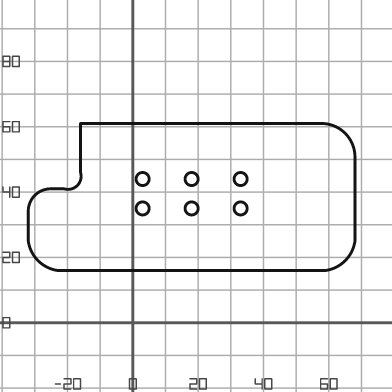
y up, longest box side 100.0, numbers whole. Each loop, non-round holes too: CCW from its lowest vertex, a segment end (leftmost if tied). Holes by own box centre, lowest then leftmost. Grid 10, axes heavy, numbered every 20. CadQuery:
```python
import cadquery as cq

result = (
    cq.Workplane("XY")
    .moveTo(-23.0, 16.0)
    .lineTo(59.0, 16.0)
    .threePointArc((65.0, 19.0), (68.0, 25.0))
    .lineTo(68.0, 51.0)
    .threePointArc((65.0, 58.0), (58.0, 61.0))
    .lineTo(-16.0, 61.0)
    .lineTo(-16.0, 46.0)
    .threePointArc((-17.0, 42.0), (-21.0, 41.0))
    .lineTo(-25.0, 41.0)
    .threePointArc((-30.0, 39.0), (-32.0, 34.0))
    .lineTo(-32.0, 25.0)
    .threePointArc((-29.0, 19.0), (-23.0, 16.0))
    .close()
    .moveTo(3.0, 35.0)
    .circle(2.0)
    .moveTo(18.0, 35.0)
    .circle(2.0)
    .moveTo(33.0, 35.0)
    .circle(2.0)
    .moveTo(3.0, 44.0)
    .circle(2.0)
    .moveTo(18.0, 44.0)
    .circle(2.0)
    .moveTo(33.0, 44.0)
    .circle(2.0)
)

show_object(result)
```